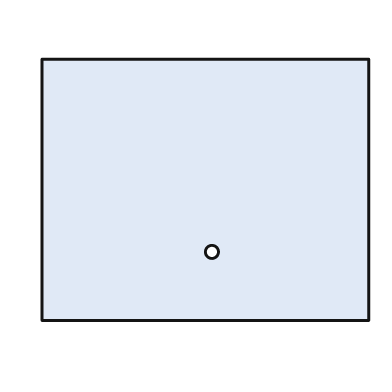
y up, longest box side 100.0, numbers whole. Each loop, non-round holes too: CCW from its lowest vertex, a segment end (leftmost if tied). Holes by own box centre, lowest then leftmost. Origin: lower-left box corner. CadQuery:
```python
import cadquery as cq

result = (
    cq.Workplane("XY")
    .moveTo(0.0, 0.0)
    .lineTo(100.0, 0.0)
    .lineTo(100.0, 80.0)
    .lineTo(0.0, 80.0)
    .close()
    .moveTo(52.0, 21.0)
    .circle(2.0)
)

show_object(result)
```